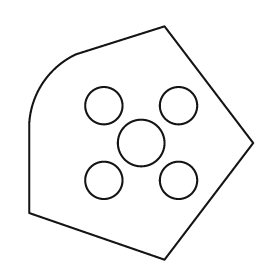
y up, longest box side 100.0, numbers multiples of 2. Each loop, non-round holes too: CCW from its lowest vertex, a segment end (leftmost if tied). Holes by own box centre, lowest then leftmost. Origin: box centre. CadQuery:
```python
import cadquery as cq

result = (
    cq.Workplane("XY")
    .moveTo(10.0, -50.0)
    .lineTo(48.0, 0.0)
    .lineTo(10.0, 50.0)
    .lineTo(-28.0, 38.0)
    .threePointArc((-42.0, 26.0), (-48.0, 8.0))
    .lineTo(-48.0, -30.0)
    .close()
    .moveTo(-16.0, -16.0)
    .circle(8.0)
    .moveTo(16.0, -16.0)
    .circle(8.0)
    .moveTo(0.0, 0.0)
    .circle(10.0)
    .moveTo(-16.0, 16.0)
    .circle(8.0)
    .moveTo(16.0, 16.0)
    .circle(8.0)
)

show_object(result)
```